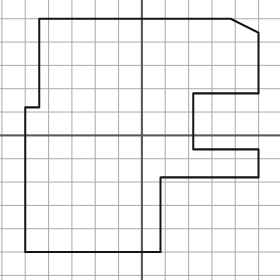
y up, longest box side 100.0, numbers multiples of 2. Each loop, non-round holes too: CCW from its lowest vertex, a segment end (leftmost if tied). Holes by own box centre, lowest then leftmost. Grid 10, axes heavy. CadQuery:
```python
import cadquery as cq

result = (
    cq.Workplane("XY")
    .moveTo(-50.0, -50.0)
    .lineTo(8.0, -50.0)
    .lineTo(8.0, -18.0)
    .lineTo(50.0, -18.0)
    .lineTo(50.0, -6.0)
    .lineTo(22.0, -6.0)
    .lineTo(22.0, 18.0)
    .lineTo(50.0, 18.0)
    .lineTo(50.0, 44.0)
    .lineTo(38.0, 50.0)
    .lineTo(-44.0, 50.0)
    .lineTo(-44.0, 12.0)
    .lineTo(-50.0, 12.0)
    .close()
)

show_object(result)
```